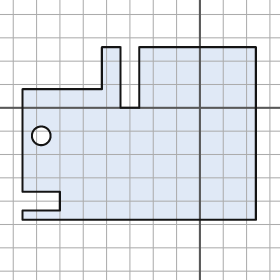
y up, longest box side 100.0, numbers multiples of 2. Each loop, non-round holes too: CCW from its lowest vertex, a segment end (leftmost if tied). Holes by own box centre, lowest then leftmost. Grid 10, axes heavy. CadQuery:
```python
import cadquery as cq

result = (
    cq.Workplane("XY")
    .moveTo(-76.0, -48.0)
    .lineTo(24.0, -48.0)
    .lineTo(24.0, 26.0)
    .lineTo(-26.0, 26.0)
    .lineTo(-26.0, 0.0)
    .lineTo(-34.0, 0.0)
    .lineTo(-34.0, 26.0)
    .lineTo(-42.0, 26.0)
    .lineTo(-42.0, 8.0)
    .lineTo(-76.0, 8.0)
    .lineTo(-76.0, -36.0)
    .lineTo(-60.0, -36.0)
    .lineTo(-60.0, -44.0)
    .lineTo(-76.0, -44.0)
    .close()
    .moveTo(-68.0, -12.0)
    .circle(4.0)
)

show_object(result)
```